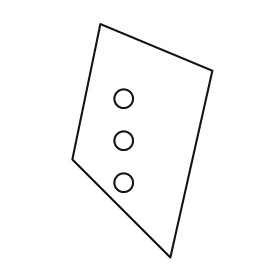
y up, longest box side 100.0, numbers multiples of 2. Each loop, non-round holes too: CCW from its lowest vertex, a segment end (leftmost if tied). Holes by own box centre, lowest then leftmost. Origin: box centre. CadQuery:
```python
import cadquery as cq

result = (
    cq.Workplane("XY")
    .moveTo(12.0, -50.0)
    .lineTo(30.0, 30.0)
    .lineTo(-18.0, 50.0)
    .lineTo(-30.0, -8.0)
    .close()
    .moveTo(-8.0, -18.0)
    .circle(4.0)
    .moveTo(-8.0, 0.0)
    .circle(4.0)
    .moveTo(-8.0, 18.0)
    .circle(4.0)
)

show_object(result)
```